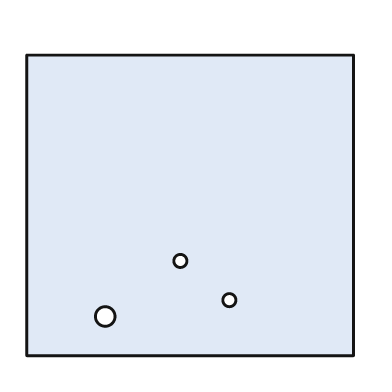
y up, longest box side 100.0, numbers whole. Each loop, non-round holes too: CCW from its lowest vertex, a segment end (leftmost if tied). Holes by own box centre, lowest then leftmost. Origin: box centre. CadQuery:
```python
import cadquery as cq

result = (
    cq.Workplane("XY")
    .moveTo(-50.0, -46.0)
    .lineTo(50.0, -46.0)
    .lineTo(50.0, 46.0)
    .lineTo(-50.0, 46.0)
    .close()
    .moveTo(-26.0, -34.0)
    .circle(3.0)
    .moveTo(12.0, -29.0)
    .circle(2.0)
    .moveTo(-3.0, -17.0)
    .circle(2.0)
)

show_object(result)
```